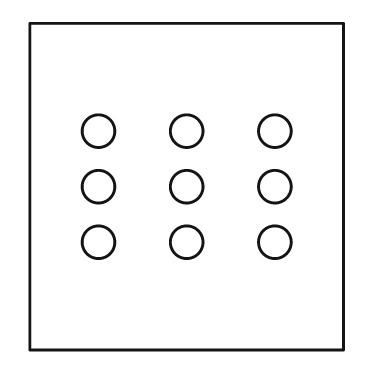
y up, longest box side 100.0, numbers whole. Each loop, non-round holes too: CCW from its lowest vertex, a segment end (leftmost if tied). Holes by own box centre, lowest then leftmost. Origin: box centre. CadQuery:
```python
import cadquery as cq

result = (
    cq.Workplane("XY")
    .moveTo(-48.0, -50.0)
    .lineTo(48.0, -50.0)
    .lineTo(48.0, 50.0)
    .lineTo(-48.0, 50.0)
    .close()
    .moveTo(-27.0, -17.0)
    .circle(5.0)
    .moveTo(0.0, -17.0)
    .circle(5.0)
    .moveTo(27.0, -17.0)
    .circle(5.0)
    .moveTo(-27.0, 0.0)
    .circle(5.0)
    .moveTo(0.0, 0.0)
    .circle(5.0)
    .moveTo(27.0, 0.0)
    .circle(5.0)
    .moveTo(-27.0, 17.0)
    .circle(5.0)
    .moveTo(0.0, 17.0)
    .circle(5.0)
    .moveTo(27.0, 17.0)
    .circle(5.0)
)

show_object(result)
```